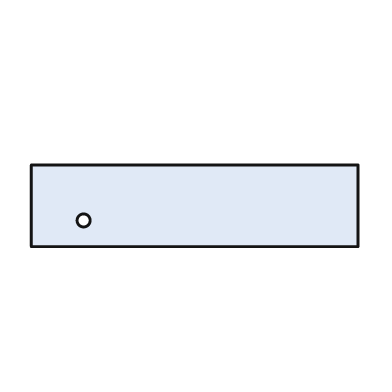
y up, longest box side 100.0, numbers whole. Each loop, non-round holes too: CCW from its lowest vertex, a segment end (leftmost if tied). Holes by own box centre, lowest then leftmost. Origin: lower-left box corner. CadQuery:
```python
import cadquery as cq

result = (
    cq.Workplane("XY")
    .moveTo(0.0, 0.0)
    .lineTo(100.0, 0.0)
    .lineTo(100.0, 25.0)
    .lineTo(0.0, 25.0)
    .close()
    .moveTo(16.0, 8.0)
    .circle(2.0)
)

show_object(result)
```